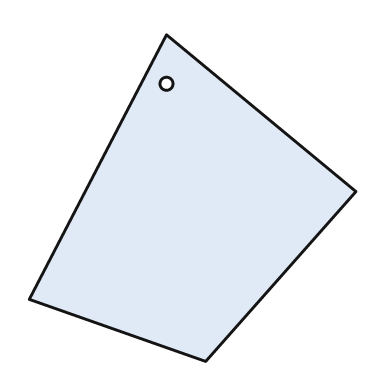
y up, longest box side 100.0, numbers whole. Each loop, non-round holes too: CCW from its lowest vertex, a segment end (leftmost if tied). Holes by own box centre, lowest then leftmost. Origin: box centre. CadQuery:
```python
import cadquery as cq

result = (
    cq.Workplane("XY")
    .moveTo(4.0, -50.0)
    .lineTo(50.0, 2.0)
    .lineTo(-8.0, 50.0)
    .lineTo(-50.0, -31.0)
    .close()
    .moveTo(-8.0, 35.0)
    .circle(2.0)
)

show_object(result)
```